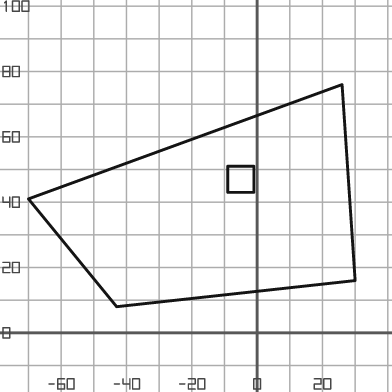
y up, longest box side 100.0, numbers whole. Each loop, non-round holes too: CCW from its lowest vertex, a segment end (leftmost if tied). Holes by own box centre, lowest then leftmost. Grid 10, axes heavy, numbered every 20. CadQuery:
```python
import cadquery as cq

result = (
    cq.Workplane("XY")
    .moveTo(-43.0, 8.0)
    .lineTo(30.0, 16.0)
    .lineTo(26.0, 76.0)
    .lineTo(-70.0, 41.0)
    .close()
    .moveTo(-9.0, 43.0)
    .lineTo(-1.0, 43.0)
    .lineTo(-1.0, 51.0)
    .lineTo(-9.0, 51.0)
    .close()
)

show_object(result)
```